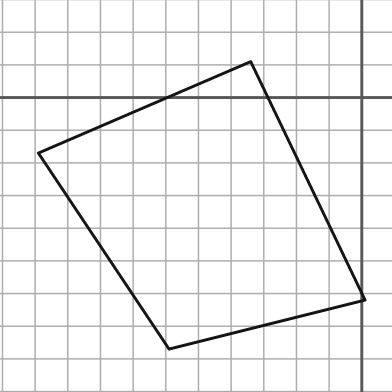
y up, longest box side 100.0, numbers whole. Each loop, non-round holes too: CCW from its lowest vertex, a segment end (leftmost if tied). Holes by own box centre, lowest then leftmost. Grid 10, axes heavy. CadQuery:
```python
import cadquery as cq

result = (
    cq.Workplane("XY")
    .moveTo(-59.0, -77.0)
    .lineTo(1.0, -62.0)
    .lineTo(-34.0, 11.0)
    .lineTo(-99.0, -17.0)
    .close()
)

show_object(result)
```